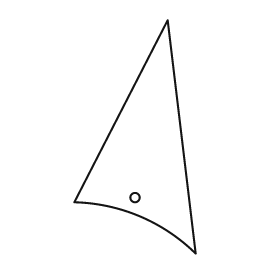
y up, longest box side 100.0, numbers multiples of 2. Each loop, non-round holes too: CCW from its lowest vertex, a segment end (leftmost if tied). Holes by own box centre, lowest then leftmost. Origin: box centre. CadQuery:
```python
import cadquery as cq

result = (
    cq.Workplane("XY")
    .moveTo(26.0, -50.0)
    .lineTo(14.0, 50.0)
    .lineTo(-26.0, -28.0)
    .threePointArc((2.0, -34.0), (26.0, -50.0))
    .close()
    .moveTo(0.0, -26.0)
    .circle(2.0)
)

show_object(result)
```